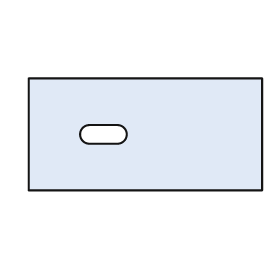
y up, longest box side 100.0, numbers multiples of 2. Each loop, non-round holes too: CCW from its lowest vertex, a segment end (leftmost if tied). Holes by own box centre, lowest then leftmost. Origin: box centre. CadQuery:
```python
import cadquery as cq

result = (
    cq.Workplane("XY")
    .moveTo(-50.0, -24.0)
    .lineTo(50.0, -24.0)
    .lineTo(50.0, 24.0)
    .lineTo(-50.0, 24.0)
    .close()
    .moveTo(-24.0, -4.0)
    .lineTo(-12.0, -4.0)
    .threePointArc((-8.0, 0.0), (-12.0, 4.0))
    .lineTo(-24.0, 4.0)
    .threePointArc((-28.0, 0.0), (-24.0, -4.0))
    .close()
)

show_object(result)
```